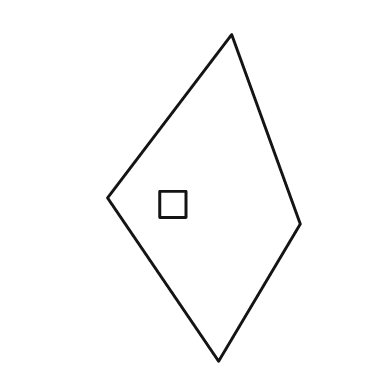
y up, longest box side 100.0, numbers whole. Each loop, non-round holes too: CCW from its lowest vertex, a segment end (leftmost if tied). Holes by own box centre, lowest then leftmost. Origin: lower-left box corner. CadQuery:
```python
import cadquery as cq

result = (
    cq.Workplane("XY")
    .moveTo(34.0, 0.0)
    .lineTo(59.0, 42.0)
    .lineTo(38.0, 100.0)
    .lineTo(0.0, 50.0)
    .close()
    .moveTo(16.0, 44.0)
    .lineTo(24.0, 44.0)
    .lineTo(24.0, 52.0)
    .lineTo(16.0, 52.0)
    .close()
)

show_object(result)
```